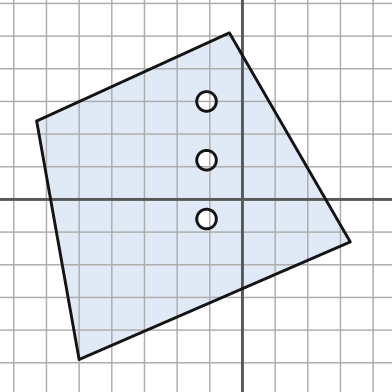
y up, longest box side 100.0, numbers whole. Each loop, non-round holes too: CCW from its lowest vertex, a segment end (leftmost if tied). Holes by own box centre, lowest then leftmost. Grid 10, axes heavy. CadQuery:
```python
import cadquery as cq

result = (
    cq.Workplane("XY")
    .moveTo(-50.0, -49.0)
    .lineTo(33.0, -13.0)
    .lineTo(-4.0, 51.0)
    .lineTo(-63.0, 24.0)
    .close()
    .moveTo(-11.0, -6.0)
    .circle(3.0)
    .moveTo(-11.0, 12.0)
    .circle(3.0)
    .moveTo(-11.0, 30.0)
    .circle(3.0)
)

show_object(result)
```